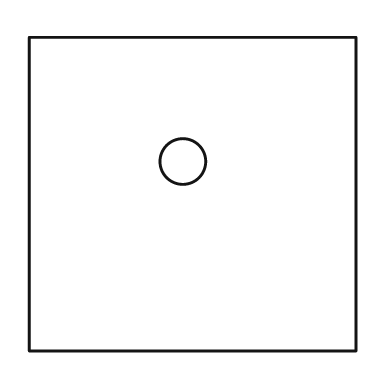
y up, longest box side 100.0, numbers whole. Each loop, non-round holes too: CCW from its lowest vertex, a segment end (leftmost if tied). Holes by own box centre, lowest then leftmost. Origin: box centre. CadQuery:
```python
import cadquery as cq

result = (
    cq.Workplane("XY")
    .moveTo(-50.0, -48.0)
    .lineTo(50.0, -48.0)
    .lineTo(50.0, 48.0)
    .lineTo(-50.0, 48.0)
    .close()
    .moveTo(-3.0, 10.0)
    .circle(7.0)
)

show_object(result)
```